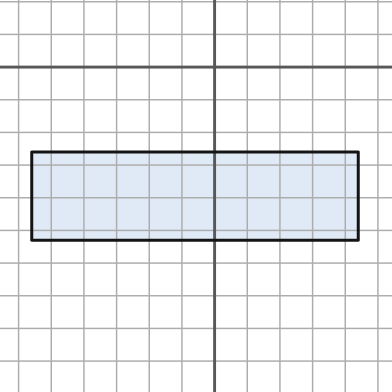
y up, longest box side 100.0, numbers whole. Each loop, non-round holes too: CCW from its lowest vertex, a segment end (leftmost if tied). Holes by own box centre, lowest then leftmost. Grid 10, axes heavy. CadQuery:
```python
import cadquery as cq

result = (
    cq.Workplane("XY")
    .moveTo(-56.0, -53.0)
    .lineTo(44.0, -53.0)
    .lineTo(44.0, -26.0)
    .lineTo(-56.0, -26.0)
    .close()
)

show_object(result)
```